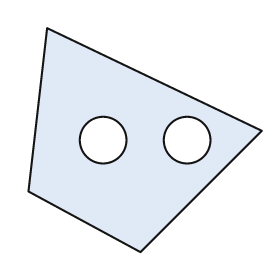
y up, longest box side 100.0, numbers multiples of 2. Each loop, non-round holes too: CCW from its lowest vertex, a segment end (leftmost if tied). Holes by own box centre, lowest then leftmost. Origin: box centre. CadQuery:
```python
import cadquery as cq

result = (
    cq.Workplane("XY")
    .moveTo(-2.0, -48.0)
    .lineTo(50.0, 4.0)
    .lineTo(-42.0, 48.0)
    .lineTo(-50.0, -22.0)
    .close()
    .moveTo(-18.0, 0.0)
    .circle(10.0)
    .moveTo(18.0, 0.0)
    .circle(10.0)
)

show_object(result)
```